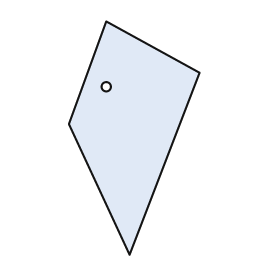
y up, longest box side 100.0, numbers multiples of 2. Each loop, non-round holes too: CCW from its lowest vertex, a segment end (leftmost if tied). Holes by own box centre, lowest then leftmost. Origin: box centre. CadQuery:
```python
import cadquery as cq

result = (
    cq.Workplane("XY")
    .moveTo(-2.0, -50.0)
    .lineTo(28.0, 28.0)
    .lineTo(-12.0, 50.0)
    .lineTo(-28.0, 6.0)
    .close()
    .moveTo(-12.0, 22.0)
    .circle(2.0)
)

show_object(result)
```